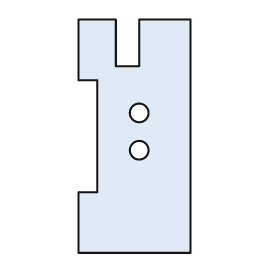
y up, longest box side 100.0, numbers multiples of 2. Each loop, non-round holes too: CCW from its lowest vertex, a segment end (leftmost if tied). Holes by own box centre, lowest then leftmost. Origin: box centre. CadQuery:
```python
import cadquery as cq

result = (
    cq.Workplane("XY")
    .moveTo(-24.0, -50.0)
    .lineTo(24.0, -50.0)
    .lineTo(24.0, 50.0)
    .lineTo(2.0, 50.0)
    .lineTo(2.0, 30.0)
    .lineTo(-8.0, 30.0)
    .lineTo(-8.0, 50.0)
    .lineTo(-24.0, 50.0)
    .lineTo(-24.0, 24.0)
    .lineTo(-16.0, 24.0)
    .lineTo(-16.0, -24.0)
    .lineTo(-24.0, -24.0)
    .close()
    .moveTo(2.0, -6.0)
    .circle(4.0)
    .moveTo(2.0, 10.0)
    .circle(4.0)
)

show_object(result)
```